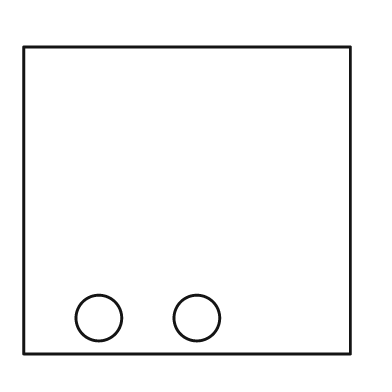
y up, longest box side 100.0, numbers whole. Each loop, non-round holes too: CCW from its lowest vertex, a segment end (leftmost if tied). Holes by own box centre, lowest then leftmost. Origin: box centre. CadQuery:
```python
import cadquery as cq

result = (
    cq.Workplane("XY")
    .moveTo(-50.0, -47.0)
    .lineTo(50.0, -47.0)
    .lineTo(50.0, 47.0)
    .lineTo(-50.0, 47.0)
    .close()
    .moveTo(-27.0, -36.0)
    .circle(7.0)
    .moveTo(3.0, -36.0)
    .circle(7.0)
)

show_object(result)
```